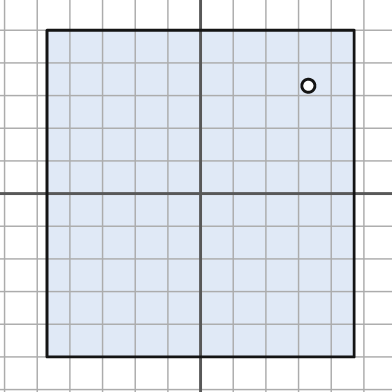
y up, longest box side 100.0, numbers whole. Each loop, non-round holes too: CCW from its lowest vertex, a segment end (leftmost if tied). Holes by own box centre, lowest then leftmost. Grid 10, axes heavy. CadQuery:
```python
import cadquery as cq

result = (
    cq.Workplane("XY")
    .moveTo(-47.0, -50.0)
    .lineTo(47.0, -50.0)
    .lineTo(47.0, 50.0)
    .lineTo(-47.0, 50.0)
    .close()
    .moveTo(33.0, 33.0)
    .circle(2.0)
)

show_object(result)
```